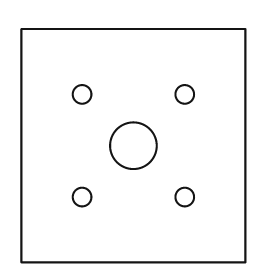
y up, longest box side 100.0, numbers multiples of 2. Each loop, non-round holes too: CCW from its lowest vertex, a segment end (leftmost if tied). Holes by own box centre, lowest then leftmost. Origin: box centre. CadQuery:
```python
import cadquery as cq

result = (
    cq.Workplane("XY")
    .moveTo(-48.0, -50.0)
    .lineTo(48.0, -50.0)
    .lineTo(48.0, 50.0)
    .lineTo(-48.0, 50.0)
    .close()
    .moveTo(-22.0, -22.0)
    .circle(4.0)
    .moveTo(22.0, -22.0)
    .circle(4.0)
    .moveTo(0.0, 0.0)
    .circle(10.0)
    .moveTo(-22.0, 22.0)
    .circle(4.0)
    .moveTo(22.0, 22.0)
    .circle(4.0)
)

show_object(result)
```